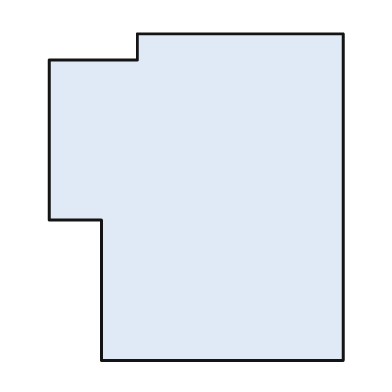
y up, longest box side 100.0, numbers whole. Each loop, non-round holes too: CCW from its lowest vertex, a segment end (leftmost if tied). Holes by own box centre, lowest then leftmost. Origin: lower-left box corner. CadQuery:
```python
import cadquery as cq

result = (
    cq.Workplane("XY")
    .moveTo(16.0, 0.0)
    .lineTo(90.0, 0.0)
    .lineTo(90.0, 100.0)
    .lineTo(27.0, 100.0)
    .lineTo(27.0, 92.0)
    .lineTo(0.0, 92.0)
    .lineTo(0.0, 43.0)
    .lineTo(16.0, 43.0)
    .close()
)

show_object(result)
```